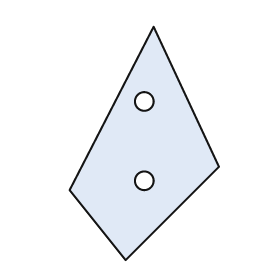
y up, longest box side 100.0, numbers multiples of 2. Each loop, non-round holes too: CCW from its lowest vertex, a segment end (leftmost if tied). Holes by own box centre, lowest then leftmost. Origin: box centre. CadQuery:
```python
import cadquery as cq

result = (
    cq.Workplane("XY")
    .moveTo(-8.0, -50.0)
    .lineTo(32.0, -10.0)
    .lineTo(4.0, 50.0)
    .lineTo(-32.0, -20.0)
    .close()
    .moveTo(0.0, -16.0)
    .circle(4.0)
    .moveTo(0.0, 18.0)
    .circle(4.0)
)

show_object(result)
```